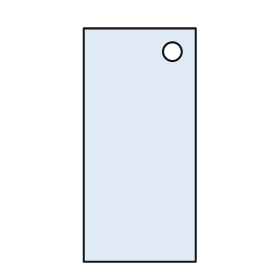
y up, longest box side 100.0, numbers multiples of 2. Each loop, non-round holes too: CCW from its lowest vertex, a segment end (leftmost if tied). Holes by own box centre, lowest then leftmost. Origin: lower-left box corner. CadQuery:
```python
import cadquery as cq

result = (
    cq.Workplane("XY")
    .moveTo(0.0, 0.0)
    .lineTo(48.0, 0.0)
    .lineTo(48.0, 100.0)
    .lineTo(0.0, 100.0)
    .close()
    .moveTo(38.0, 90.0)
    .circle(4.0)
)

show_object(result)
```